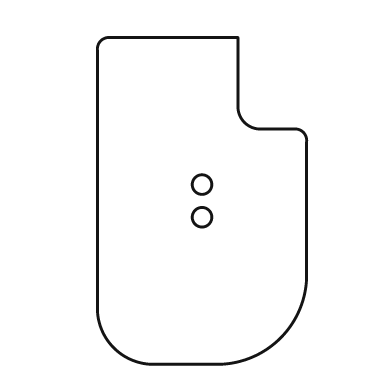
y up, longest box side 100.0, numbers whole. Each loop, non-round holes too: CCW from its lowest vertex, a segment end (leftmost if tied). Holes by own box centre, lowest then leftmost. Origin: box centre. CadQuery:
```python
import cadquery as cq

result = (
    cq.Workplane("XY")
    .moveTo(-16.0, -50.0)
    .lineTo(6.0, -50.0)
    .threePointArc((24.0, -42.0), (32.0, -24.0))
    .lineTo(32.0, 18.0)
    .threePointArc((31.0, 21.0), (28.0, 22.0))
    .lineTo(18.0, 22.0)
    .threePointArc((13.0, 24.0), (11.0, 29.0))
    .lineTo(11.0, 50.0)
    .lineTo(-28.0, 50.0)
    .threePointArc((-31.0, 49.0), (-32.0, 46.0))
    .lineTo(-32.0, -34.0)
    .threePointArc((-27.0, -45.0), (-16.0, -50.0))
    .close()
    .moveTo(0.0, -5.0)
    .circle(3.0)
    .moveTo(0.0, 5.0)
    .circle(3.0)
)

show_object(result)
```